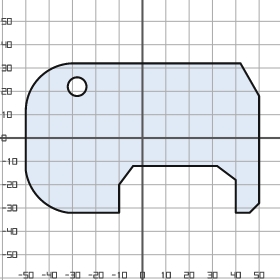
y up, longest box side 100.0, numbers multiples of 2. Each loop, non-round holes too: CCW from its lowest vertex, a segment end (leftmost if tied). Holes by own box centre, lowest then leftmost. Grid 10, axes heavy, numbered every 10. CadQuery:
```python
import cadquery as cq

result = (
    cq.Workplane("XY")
    .moveTo(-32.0, -32.0)
    .lineTo(-10.0, -32.0)
    .lineTo(-10.0, -20.0)
    .lineTo(-4.0, -12.0)
    .lineTo(32.0, -12.0)
    .lineTo(40.0, -18.0)
    .lineTo(40.0, -32.0)
    .lineTo(46.0, -32.0)
    .lineTo(50.0, -28.0)
    .lineTo(50.0, 18.0)
    .lineTo(42.0, 32.0)
    .lineTo(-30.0, 32.0)
    .threePointArc((-44.0, 26.0), (-50.0, 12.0))
    .lineTo(-50.0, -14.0)
    .threePointArc((-44.0, -26.0), (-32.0, -32.0))
    .close()
    .moveTo(-28.0, 22.0)
    .circle(4.0)
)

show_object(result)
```